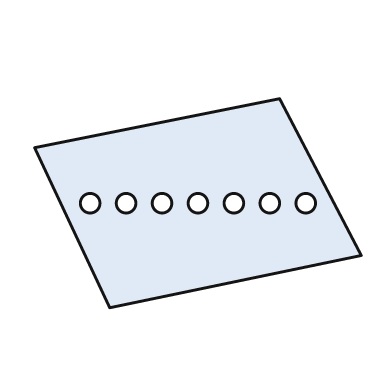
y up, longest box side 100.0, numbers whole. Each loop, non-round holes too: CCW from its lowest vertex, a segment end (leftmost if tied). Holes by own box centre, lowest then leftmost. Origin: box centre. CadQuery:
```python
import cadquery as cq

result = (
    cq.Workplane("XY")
    .moveTo(-27.0, -32.0)
    .lineTo(50.0, -16.0)
    .lineTo(25.0, 32.0)
    .lineTo(-50.0, 17.0)
    .close()
    .moveTo(-33.0, 0.0)
    .circle(3.0)
    .moveTo(-22.0, 0.0)
    .circle(3.0)
    .moveTo(-11.0, 0.0)
    .circle(3.0)
    .moveTo(0.0, 0.0)
    .circle(3.0)
    .moveTo(11.0, 0.0)
    .circle(3.0)
    .moveTo(22.0, 0.0)
    .circle(3.0)
    .moveTo(33.0, 0.0)
    .circle(3.0)
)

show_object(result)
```